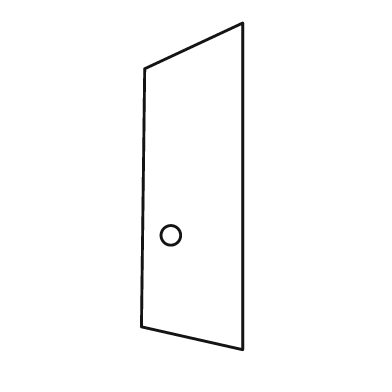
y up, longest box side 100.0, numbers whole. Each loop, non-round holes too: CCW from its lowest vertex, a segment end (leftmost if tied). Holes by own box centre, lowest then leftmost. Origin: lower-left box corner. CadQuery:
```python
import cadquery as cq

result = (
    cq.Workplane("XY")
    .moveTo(31.0, 0.0)
    .lineTo(31.0, 100.0)
    .lineTo(1.0, 86.0)
    .lineTo(0.0, 7.0)
    .close()
    .moveTo(9.0, 35.0)
    .circle(3.0)
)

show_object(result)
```